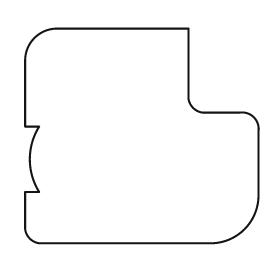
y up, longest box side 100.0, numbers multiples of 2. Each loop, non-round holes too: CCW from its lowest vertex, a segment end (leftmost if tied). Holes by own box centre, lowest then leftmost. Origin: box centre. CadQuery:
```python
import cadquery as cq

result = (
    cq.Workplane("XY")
    .moveTo(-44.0, -46.0)
    .lineTo(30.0, -46.0)
    .threePointArc((44.0, -40.0), (50.0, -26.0))
    .lineTo(50.0, 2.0)
    .threePointArc((48.0, 8.0), (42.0, 10.0))
    .lineTo(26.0, 10.0)
    .threePointArc((22.0, 12.0), (20.0, 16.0))
    .lineTo(20.0, 46.0)
    .lineTo(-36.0, 46.0)
    .threePointArc((-46.0, 42.0), (-50.0, 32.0))
    .lineTo(-50.0, 4.0)
    .lineTo(-44.0, 4.0)
    .threePointArc((-48.0, -10.0), (-44.0, -24.0))
    .lineTo(-50.0, -24.0)
    .lineTo(-50.0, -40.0)
    .threePointArc((-48.0, -44.0), (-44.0, -46.0))
    .close()
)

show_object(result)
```